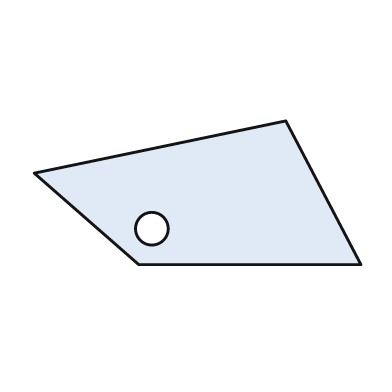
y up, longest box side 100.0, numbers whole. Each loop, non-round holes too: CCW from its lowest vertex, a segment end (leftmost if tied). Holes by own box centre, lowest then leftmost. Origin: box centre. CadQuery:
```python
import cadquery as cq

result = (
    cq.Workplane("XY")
    .moveTo(-18.0, -22.0)
    .lineTo(50.0, -22.0)
    .lineTo(27.0, 22.0)
    .lineTo(-50.0, 6.0)
    .close()
    .moveTo(-14.0, -11.0)
    .circle(5.0)
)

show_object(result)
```